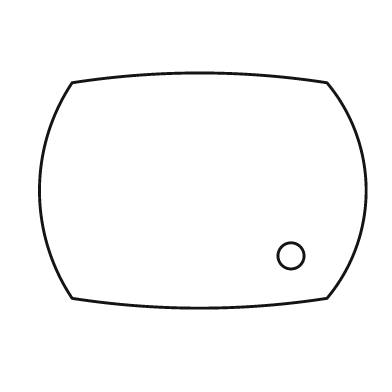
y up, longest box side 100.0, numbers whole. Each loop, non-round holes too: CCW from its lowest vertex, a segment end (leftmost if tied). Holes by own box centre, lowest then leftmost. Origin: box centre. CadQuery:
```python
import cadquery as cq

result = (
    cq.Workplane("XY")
    .moveTo(-40.0, -33.0)
    .threePointArc((-1.0, -36.0), (38.0, -33.0))
    .threePointArc((50.0, 0.0), (38.0, 33.0))
    .threePointArc((-1.0, 36.0), (-40.0, 33.0))
    .threePointArc((-50.0, 0.0), (-40.0, -33.0))
    .close()
    .moveTo(27.0, -20.0)
    .circle(4.0)
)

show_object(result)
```